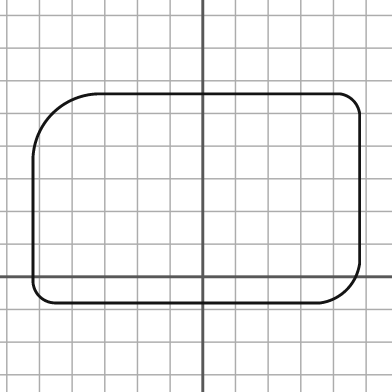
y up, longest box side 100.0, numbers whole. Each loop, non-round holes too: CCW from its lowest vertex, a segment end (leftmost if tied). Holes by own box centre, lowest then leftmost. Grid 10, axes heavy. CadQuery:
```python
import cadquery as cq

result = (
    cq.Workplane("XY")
    .moveTo(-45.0, -8.0)
    .lineTo(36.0, -8.0)
    .threePointArc((44.0, -4.0), (48.0, 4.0))
    .lineTo(48.0, 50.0)
    .threePointArc((46.0, 54.0), (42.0, 56.0))
    .lineTo(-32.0, 56.0)
    .threePointArc((-46.0, 50.0), (-52.0, 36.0))
    .lineTo(-52.0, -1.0)
    .threePointArc((-50.0, -6.0), (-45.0, -8.0))
    .close()
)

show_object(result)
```